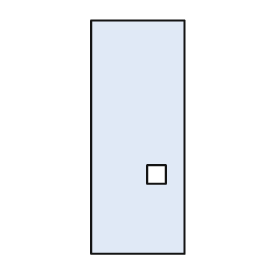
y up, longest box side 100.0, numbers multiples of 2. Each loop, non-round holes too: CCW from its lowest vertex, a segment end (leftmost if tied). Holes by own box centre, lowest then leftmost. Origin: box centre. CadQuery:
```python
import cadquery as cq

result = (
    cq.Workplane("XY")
    .moveTo(-20.0, -50.0)
    .lineTo(20.0, -50.0)
    .lineTo(20.0, 50.0)
    .lineTo(-20.0, 50.0)
    .close()
    .moveTo(4.0, -20.0)
    .lineTo(12.0, -20.0)
    .lineTo(12.0, -12.0)
    .lineTo(4.0, -12.0)
    .close()
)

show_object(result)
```